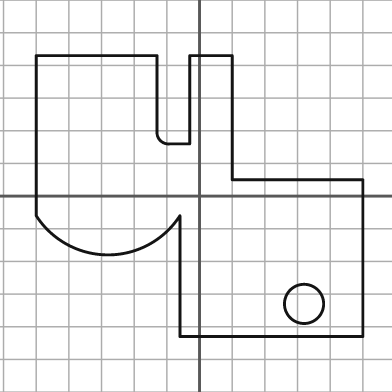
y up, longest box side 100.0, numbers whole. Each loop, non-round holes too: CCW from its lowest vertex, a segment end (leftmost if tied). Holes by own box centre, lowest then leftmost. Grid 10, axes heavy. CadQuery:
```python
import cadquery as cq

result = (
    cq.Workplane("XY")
    .moveTo(-6.0, -43.0)
    .lineTo(50.0, -43.0)
    .lineTo(50.0, 5.0)
    .lineTo(10.0, 5.0)
    .lineTo(10.0, 43.0)
    .lineTo(-3.0, 43.0)
    .lineTo(-3.0, 16.0)
    .lineTo(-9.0, 16.0)
    .threePointArc((-12.0, 17.0), (-13.0, 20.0))
    .lineTo(-13.0, 43.0)
    .lineTo(-50.0, 43.0)
    .lineTo(-50.0, -6.0)
    .threePointArc((-28.0, -18.0), (-6.0, -6.0))
    .close()
    .moveTo(32.0, -33.0)
    .circle(6.0)
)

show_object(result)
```